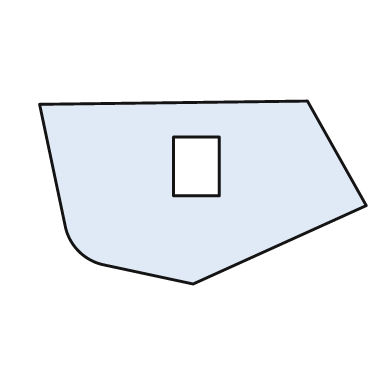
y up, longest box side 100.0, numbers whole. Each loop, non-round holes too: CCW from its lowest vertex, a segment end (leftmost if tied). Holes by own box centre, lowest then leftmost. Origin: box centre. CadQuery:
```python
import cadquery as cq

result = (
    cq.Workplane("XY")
    .moveTo(-3.0, -28.0)
    .lineTo(50.0, -4.0)
    .lineTo(32.0, 28.0)
    .lineTo(-50.0, 27.0)
    .lineTo(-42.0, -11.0)
    .threePointArc((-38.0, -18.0), (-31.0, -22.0))
    .close()
    .moveTo(-9.0, -1.0)
    .lineTo(5.0, -1.0)
    .lineTo(5.0, 17.0)
    .lineTo(-9.0, 17.0)
    .close()
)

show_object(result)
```